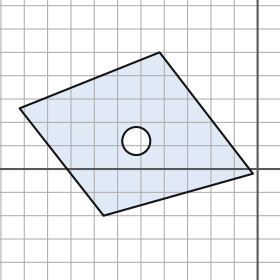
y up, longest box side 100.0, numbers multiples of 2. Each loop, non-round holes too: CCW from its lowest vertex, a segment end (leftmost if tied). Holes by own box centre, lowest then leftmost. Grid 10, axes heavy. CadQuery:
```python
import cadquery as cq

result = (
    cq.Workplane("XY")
    .moveTo(-66.0, -20.0)
    .lineTo(-2.0, -2.0)
    .lineTo(-42.0, 50.0)
    .lineTo(-102.0, 26.0)
    .close()
    .moveTo(-52.0, 12.0)
    .circle(6.0)
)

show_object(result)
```